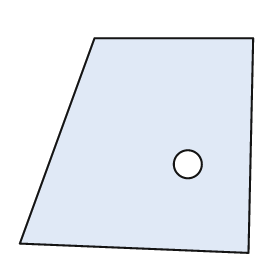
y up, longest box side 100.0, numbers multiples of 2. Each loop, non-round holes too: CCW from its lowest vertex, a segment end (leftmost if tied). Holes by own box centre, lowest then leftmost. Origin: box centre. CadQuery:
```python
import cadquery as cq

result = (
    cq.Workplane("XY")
    .moveTo(48.0, -46.0)
    .lineTo(50.0, 46.0)
    .lineTo(-18.0, 46.0)
    .lineTo(-50.0, -42.0)
    .close()
    .moveTo(22.0, -8.0)
    .circle(6.0)
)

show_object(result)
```